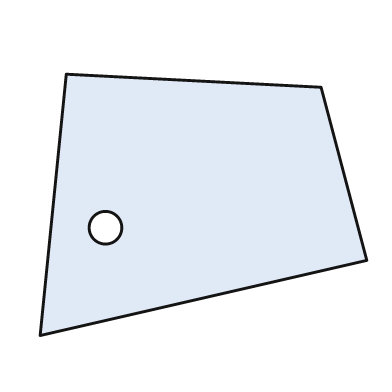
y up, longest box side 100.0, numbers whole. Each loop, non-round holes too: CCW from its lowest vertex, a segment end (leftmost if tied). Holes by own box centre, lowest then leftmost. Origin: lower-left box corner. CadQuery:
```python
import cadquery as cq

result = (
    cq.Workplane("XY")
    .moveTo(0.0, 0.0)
    .lineTo(100.0, 23.0)
    .lineTo(86.0, 76.0)
    .lineTo(8.0, 80.0)
    .close()
    .moveTo(20.0, 33.0)
    .circle(5.0)
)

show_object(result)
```